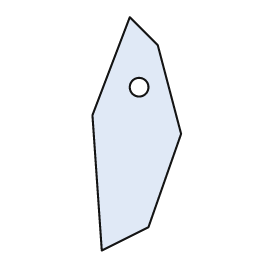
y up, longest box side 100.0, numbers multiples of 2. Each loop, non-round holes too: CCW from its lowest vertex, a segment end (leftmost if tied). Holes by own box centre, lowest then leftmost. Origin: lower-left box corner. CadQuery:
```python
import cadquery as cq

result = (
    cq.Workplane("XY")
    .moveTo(4.0, 0.0)
    .lineTo(24.0, 10.0)
    .lineTo(38.0, 50.0)
    .lineTo(28.0, 88.0)
    .lineTo(16.0, 100.0)
    .lineTo(0.0, 58.0)
    .close()
    .moveTo(20.0, 70.0)
    .circle(4.0)
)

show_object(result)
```